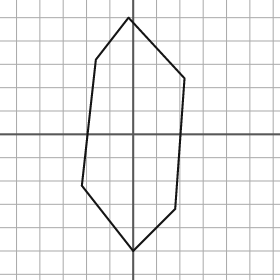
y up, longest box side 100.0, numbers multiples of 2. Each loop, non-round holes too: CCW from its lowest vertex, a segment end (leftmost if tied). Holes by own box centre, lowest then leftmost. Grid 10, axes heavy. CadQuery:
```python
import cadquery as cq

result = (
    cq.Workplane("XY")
    .moveTo(0.0, -50.0)
    .lineTo(18.0, -32.0)
    .lineTo(22.0, 24.0)
    .lineTo(-2.0, 50.0)
    .lineTo(-16.0, 32.0)
    .lineTo(-22.0, -22.0)
    .close()
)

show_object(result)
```